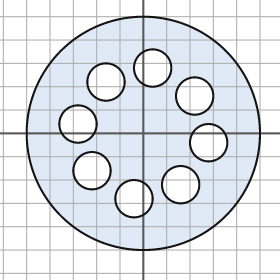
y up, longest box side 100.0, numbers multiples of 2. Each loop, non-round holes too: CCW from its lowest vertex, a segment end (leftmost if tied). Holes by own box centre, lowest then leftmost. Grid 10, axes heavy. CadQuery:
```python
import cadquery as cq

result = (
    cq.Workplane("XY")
    .moveTo(0.0, 0.0)
    .circle(50.0)
    .moveTo(-4.0, -28.0)
    .circle(8.0)
    .moveTo(16.0, -22.0)
    .circle(8.0)
    .moveTo(-22.0, -16.0)
    .circle(8.0)
    .moveTo(28.0, -4.0)
    .circle(8.0)
    .moveTo(-28.0, 4.0)
    .circle(8.0)
    .moveTo(22.0, 16.0)
    .circle(8.0)
    .moveTo(-16.0, 22.0)
    .circle(8.0)
    .moveTo(4.0, 28.0)
    .circle(8.0)
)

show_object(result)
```